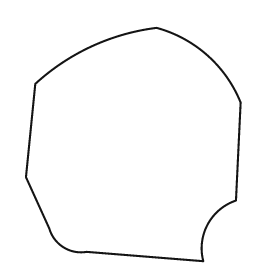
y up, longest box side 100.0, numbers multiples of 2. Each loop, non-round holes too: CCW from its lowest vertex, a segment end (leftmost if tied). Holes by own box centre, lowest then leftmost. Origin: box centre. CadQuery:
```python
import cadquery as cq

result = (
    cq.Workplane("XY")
    .moveTo(30.0, -50.0)
    .threePointArc((32.0, -34.0), (44.0, -24.0))
    .lineTo(46.0, 18.0)
    .threePointArc((32.0, 38.0), (10.0, 50.0))
    .threePointArc((-18.0, 42.0), (-42.0, 26.0))
    .lineTo(-46.0, -14.0)
    .lineTo(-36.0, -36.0)
    .threePointArc((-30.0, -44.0), (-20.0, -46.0))
    .close()
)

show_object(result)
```